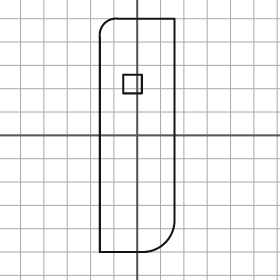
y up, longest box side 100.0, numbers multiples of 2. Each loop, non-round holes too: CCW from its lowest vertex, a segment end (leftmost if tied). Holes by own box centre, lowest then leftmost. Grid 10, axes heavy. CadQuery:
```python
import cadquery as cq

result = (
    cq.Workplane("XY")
    .moveTo(-16.0, -50.0)
    .lineTo(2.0, -50.0)
    .threePointArc((12.0, -46.0), (16.0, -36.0))
    .lineTo(16.0, 50.0)
    .lineTo(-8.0, 50.0)
    .threePointArc((-14.0, 48.0), (-16.0, 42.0))
    .close()
    .moveTo(-6.0, 18.0)
    .lineTo(2.0, 18.0)
    .lineTo(2.0, 26.0)
    .lineTo(-6.0, 26.0)
    .close()
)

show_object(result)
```